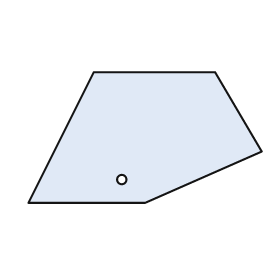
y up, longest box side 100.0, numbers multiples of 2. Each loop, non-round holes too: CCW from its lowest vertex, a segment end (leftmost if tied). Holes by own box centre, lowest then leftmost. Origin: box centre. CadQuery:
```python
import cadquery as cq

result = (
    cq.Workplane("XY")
    .moveTo(-50.0, -28.0)
    .lineTo(0.0, -28.0)
    .lineTo(50.0, -6.0)
    .lineTo(30.0, 28.0)
    .lineTo(-22.0, 28.0)
    .close()
    .moveTo(-10.0, -18.0)
    .circle(2.0)
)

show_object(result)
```